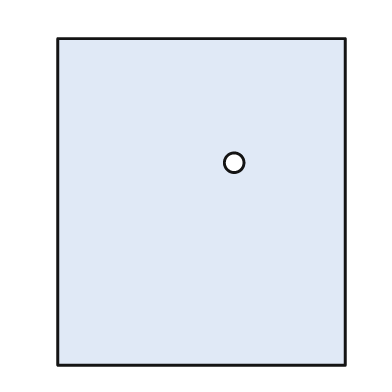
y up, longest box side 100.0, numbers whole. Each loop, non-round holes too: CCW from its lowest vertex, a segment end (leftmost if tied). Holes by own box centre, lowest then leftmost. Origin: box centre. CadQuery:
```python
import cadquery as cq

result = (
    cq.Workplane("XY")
    .moveTo(-44.0, -50.0)
    .lineTo(44.0, -50.0)
    .lineTo(44.0, 50.0)
    .lineTo(-44.0, 50.0)
    .close()
    .moveTo(10.0, 12.0)
    .circle(3.0)
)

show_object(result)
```